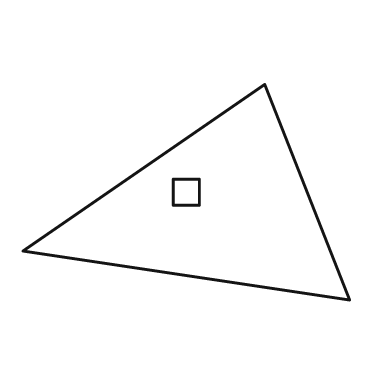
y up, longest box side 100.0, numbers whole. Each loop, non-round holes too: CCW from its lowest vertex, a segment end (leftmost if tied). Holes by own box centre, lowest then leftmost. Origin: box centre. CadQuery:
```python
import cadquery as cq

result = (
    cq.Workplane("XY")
    .moveTo(50.0, -33.0)
    .lineTo(24.0, 33.0)
    .lineTo(-50.0, -18.0)
    .close()
    .moveTo(-4.0, -4.0)
    .lineTo(4.0, -4.0)
    .lineTo(4.0, 4.0)
    .lineTo(-4.0, 4.0)
    .close()
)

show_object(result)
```